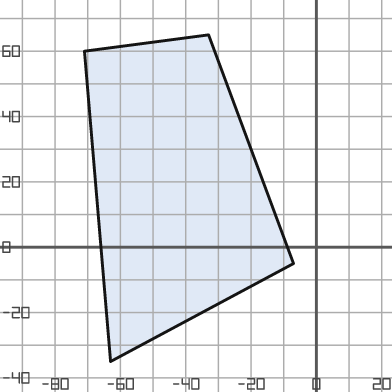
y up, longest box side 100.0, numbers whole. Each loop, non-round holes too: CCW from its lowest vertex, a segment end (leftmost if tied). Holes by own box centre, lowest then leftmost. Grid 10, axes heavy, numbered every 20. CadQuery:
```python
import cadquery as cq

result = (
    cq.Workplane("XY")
    .moveTo(-63.0, -35.0)
    .lineTo(-7.0, -5.0)
    .lineTo(-33.0, 65.0)
    .lineTo(-71.0, 60.0)
    .close()
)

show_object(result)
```